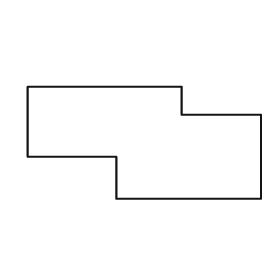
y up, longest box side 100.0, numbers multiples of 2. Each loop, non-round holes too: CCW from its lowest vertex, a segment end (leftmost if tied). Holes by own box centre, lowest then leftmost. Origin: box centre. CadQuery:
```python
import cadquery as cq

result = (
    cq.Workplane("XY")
    .moveTo(-12.0, -24.0)
    .lineTo(50.0, -24.0)
    .lineTo(50.0, 12.0)
    .lineTo(16.0, 12.0)
    .lineTo(16.0, 24.0)
    .lineTo(-50.0, 24.0)
    .lineTo(-50.0, -6.0)
    .lineTo(-12.0, -6.0)
    .close()
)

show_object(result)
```